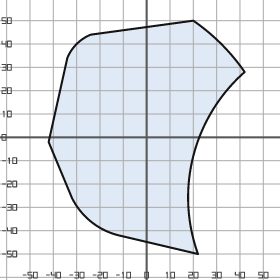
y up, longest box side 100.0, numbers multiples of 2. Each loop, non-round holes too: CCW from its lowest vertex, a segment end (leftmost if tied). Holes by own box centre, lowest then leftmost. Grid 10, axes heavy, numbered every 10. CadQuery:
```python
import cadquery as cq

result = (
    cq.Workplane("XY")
    .moveTo(22.0, -50.0)
    .threePointArc((20.0, -8.0), (42.0, 28.0))
    .threePointArc((32.0, 40.0), (20.0, 50.0))
    .lineTo(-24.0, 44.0)
    .threePointArc((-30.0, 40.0), (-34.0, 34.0))
    .lineTo(-42.0, -2.0)
    .lineTo(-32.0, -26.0)
    .threePointArc((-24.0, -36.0), (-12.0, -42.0))
    .close()
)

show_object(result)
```